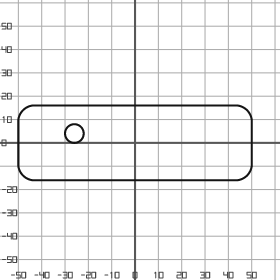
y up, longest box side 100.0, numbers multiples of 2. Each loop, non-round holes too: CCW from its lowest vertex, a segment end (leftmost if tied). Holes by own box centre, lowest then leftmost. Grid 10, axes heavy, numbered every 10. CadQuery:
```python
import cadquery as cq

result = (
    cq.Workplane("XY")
    .moveTo(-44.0, -16.0)
    .lineTo(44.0, -16.0)
    .threePointArc((48.0, -14.0), (50.0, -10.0))
    .lineTo(50.0, 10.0)
    .threePointArc((48.0, 14.0), (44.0, 16.0))
    .lineTo(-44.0, 16.0)
    .threePointArc((-48.0, 14.0), (-50.0, 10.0))
    .lineTo(-50.0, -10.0)
    .threePointArc((-48.0, -14.0), (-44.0, -16.0))
    .close()
    .moveTo(-26.0, 4.0)
    .circle(4.0)
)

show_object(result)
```